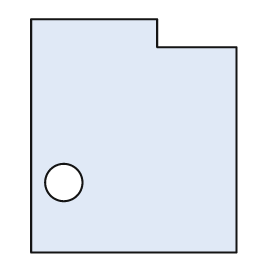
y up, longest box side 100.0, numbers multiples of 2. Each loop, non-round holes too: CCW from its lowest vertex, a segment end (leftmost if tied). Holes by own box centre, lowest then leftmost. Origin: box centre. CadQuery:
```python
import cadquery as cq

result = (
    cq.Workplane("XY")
    .moveTo(-44.0, -50.0)
    .lineTo(44.0, -50.0)
    .lineTo(44.0, 38.0)
    .lineTo(10.0, 38.0)
    .lineTo(10.0, 50.0)
    .lineTo(-44.0, 50.0)
    .close()
    .moveTo(-30.0, -20.0)
    .circle(8.0)
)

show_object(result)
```